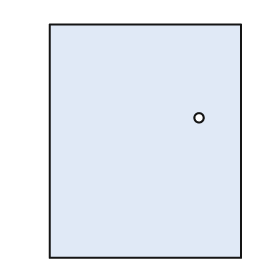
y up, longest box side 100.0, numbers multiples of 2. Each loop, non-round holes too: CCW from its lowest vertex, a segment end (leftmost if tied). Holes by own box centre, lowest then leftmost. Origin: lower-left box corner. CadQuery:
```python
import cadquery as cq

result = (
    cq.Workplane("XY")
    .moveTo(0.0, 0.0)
    .lineTo(82.0, 0.0)
    .lineTo(82.0, 100.0)
    .lineTo(0.0, 100.0)
    .close()
    .moveTo(64.0, 60.0)
    .circle(2.0)
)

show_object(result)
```